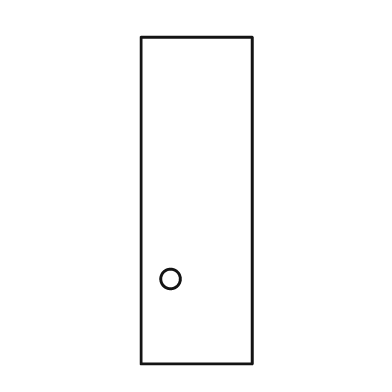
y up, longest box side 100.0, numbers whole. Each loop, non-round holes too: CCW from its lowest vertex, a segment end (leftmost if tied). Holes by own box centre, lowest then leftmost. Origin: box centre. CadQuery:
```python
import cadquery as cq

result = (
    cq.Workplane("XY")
    .moveTo(-17.0, -50.0)
    .lineTo(17.0, -50.0)
    .lineTo(17.0, 50.0)
    .lineTo(-17.0, 50.0)
    .close()
    .moveTo(-8.0, -24.0)
    .circle(3.0)
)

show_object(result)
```